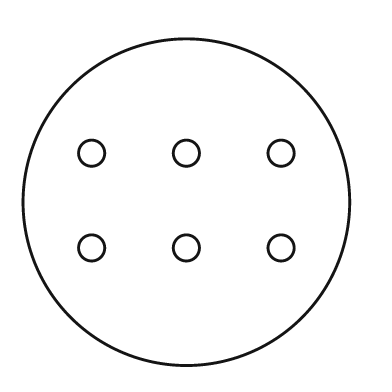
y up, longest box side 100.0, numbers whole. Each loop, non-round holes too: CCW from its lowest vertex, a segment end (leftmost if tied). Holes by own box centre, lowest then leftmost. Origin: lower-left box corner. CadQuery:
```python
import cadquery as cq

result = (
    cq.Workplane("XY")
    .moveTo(50.0, 50.0)
    .circle(50.0)
    .moveTo(21.0, 36.0)
    .circle(4.0)
    .moveTo(50.0, 36.0)
    .circle(4.0)
    .moveTo(79.0, 36.0)
    .circle(4.0)
    .moveTo(21.0, 65.0)
    .circle(4.0)
    .moveTo(50.0, 65.0)
    .circle(4.0)
    .moveTo(79.0, 65.0)
    .circle(4.0)
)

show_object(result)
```